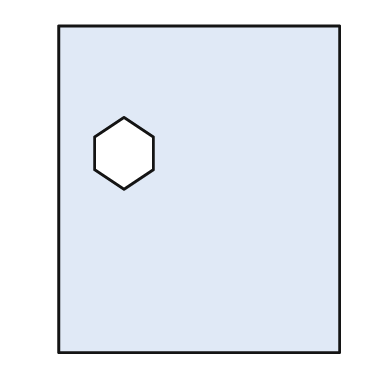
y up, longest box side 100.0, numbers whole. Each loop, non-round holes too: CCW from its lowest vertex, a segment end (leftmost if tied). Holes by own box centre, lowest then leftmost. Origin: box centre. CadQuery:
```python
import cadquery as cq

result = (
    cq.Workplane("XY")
    .moveTo(-43.0, -50.0)
    .lineTo(43.0, -50.0)
    .lineTo(43.0, 50.0)
    .lineTo(-43.0, 50.0)
    .close()
    .moveTo(-23.0, 0.0)
    .lineTo(-14.0, 6.0)
    .lineTo(-14.0, 16.0)
    .lineTo(-23.0, 22.0)
    .lineTo(-32.0, 16.0)
    .lineTo(-32.0, 6.0)
    .close()
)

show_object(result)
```